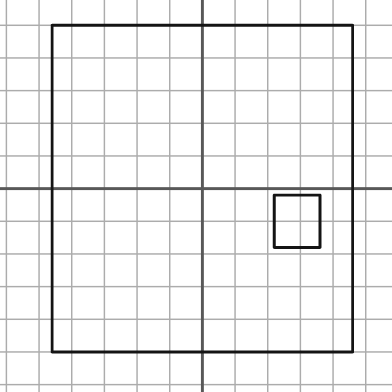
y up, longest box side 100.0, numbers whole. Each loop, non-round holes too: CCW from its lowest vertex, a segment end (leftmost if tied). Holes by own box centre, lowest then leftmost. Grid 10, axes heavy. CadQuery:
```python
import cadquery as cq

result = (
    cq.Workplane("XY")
    .moveTo(-46.0, -50.0)
    .lineTo(46.0, -50.0)
    .lineTo(46.0, 50.0)
    .lineTo(-46.0, 50.0)
    .close()
    .moveTo(22.0, -18.0)
    .lineTo(36.0, -18.0)
    .lineTo(36.0, -2.0)
    .lineTo(22.0, -2.0)
    .close()
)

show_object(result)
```